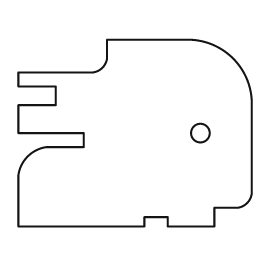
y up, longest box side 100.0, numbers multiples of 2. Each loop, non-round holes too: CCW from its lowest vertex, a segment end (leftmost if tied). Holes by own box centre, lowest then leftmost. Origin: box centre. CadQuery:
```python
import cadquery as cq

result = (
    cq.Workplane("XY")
    .moveTo(-50.0, -40.0)
    .lineTo(4.0, -40.0)
    .lineTo(4.0, -36.0)
    .lineTo(14.0, -36.0)
    .lineTo(14.0, -40.0)
    .lineTo(34.0, -40.0)
    .lineTo(34.0, -32.0)
    .lineTo(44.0, -32.0)
    .threePointArc((48.0, -30.0), (50.0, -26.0))
    .lineTo(50.0, 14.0)
    .threePointArc((42.0, 32.0), (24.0, 40.0))
    .lineTo(-12.0, 40.0)
    .lineTo(-12.0, 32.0)
    .threePointArc((-14.0, 28.0), (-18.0, 26.0))
    .lineTo(-50.0, 26.0)
    .lineTo(-50.0, 20.0)
    .lineTo(-34.0, 20.0)
    .lineTo(-34.0, 12.0)
    .lineTo(-50.0, 12.0)
    .lineTo(-50.0, 0.0)
    .lineTo(-22.0, 0.0)
    .lineTo(-22.0, -6.0)
    .lineTo(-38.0, -6.0)
    .threePointArc((-46.0, -10.0), (-50.0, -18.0))
    .close()
    .moveTo(28.0, 0.0)
    .circle(4.0)
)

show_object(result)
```